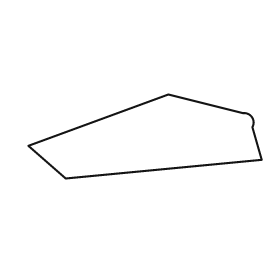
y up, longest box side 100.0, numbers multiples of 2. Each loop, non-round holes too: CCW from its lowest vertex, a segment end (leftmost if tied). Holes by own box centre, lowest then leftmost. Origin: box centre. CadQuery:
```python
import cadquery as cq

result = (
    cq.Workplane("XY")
    .moveTo(-34.0, -18.0)
    .lineTo(50.0, -10.0)
    .lineTo(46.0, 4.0)
    .threePointArc((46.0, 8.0), (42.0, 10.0))
    .lineTo(10.0, 18.0)
    .lineTo(-50.0, -4.0)
    .close()
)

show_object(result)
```